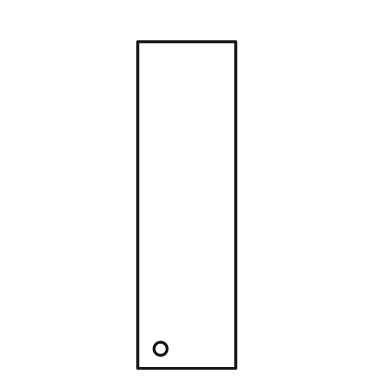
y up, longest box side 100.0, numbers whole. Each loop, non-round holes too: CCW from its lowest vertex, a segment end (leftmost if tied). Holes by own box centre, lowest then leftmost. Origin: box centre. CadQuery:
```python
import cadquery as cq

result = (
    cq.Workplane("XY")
    .moveTo(-15.0, -50.0)
    .lineTo(15.0, -50.0)
    .lineTo(15.0, 50.0)
    .lineTo(-15.0, 50.0)
    .close()
    .moveTo(-8.0, -44.0)
    .circle(2.0)
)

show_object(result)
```